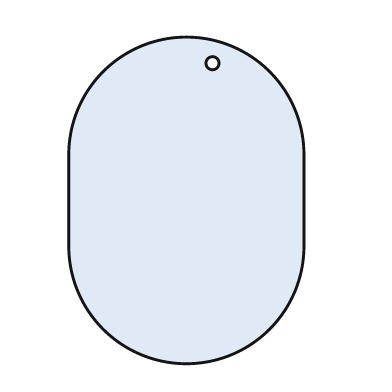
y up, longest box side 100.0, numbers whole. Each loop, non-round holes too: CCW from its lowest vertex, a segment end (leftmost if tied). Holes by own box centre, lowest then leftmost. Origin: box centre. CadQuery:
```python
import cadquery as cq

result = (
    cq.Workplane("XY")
    .moveTo(-36.0, -14.0)
    .threePointArc((0.0, -50.0), (36.0, -14.0))
    .lineTo(36.0, 14.0)
    .threePointArc((0.0, 50.0), (-36.0, 14.0))
    .close()
    .moveTo(8.0, 42.0)
    .circle(2.0)
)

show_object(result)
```